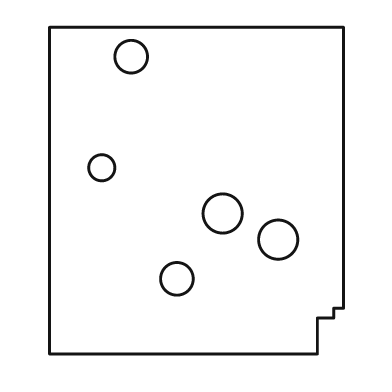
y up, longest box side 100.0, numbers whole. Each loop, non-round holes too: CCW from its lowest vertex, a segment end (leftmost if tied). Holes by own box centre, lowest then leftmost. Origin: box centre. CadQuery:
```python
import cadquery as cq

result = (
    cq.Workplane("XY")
    .moveTo(-45.0, -50.0)
    .lineTo(37.0, -50.0)
    .lineTo(37.0, -39.0)
    .lineTo(42.0, -39.0)
    .lineTo(42.0, -36.0)
    .lineTo(45.0, -36.0)
    .lineTo(45.0, 50.0)
    .lineTo(-45.0, 50.0)
    .close()
    .moveTo(-6.0, -27.0)
    .circle(5.0)
    .moveTo(25.0, -15.0)
    .circle(6.0)
    .moveTo(8.0, -7.0)
    .circle(6.0)
    .moveTo(-29.0, 7.0)
    .circle(4.0)
    .moveTo(-20.0, 41.0)
    .circle(5.0)
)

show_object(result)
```